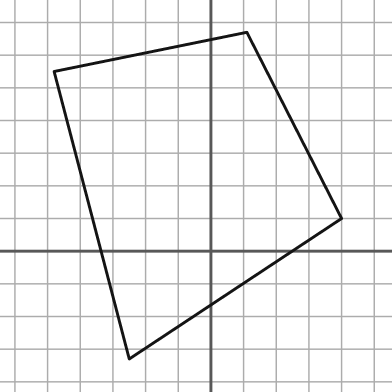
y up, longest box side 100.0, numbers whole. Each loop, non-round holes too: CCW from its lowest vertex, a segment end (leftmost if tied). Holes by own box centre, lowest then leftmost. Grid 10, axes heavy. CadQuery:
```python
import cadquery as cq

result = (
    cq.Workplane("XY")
    .moveTo(-25.0, -33.0)
    .lineTo(40.0, 10.0)
    .lineTo(11.0, 67.0)
    .lineTo(-48.0, 55.0)
    .close()
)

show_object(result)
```